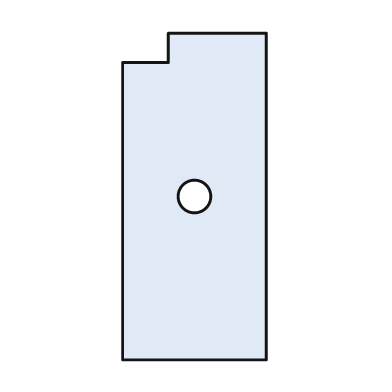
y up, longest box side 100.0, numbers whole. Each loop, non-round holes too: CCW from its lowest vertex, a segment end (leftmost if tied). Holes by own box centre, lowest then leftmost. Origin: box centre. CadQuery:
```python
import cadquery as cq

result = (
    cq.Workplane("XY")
    .moveTo(-22.0, -50.0)
    .lineTo(22.0, -50.0)
    .lineTo(22.0, 50.0)
    .lineTo(-8.0, 50.0)
    .lineTo(-8.0, 41.0)
    .lineTo(-22.0, 41.0)
    .close()
    .moveTo(0.0, 0.0)
    .circle(5.0)
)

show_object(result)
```